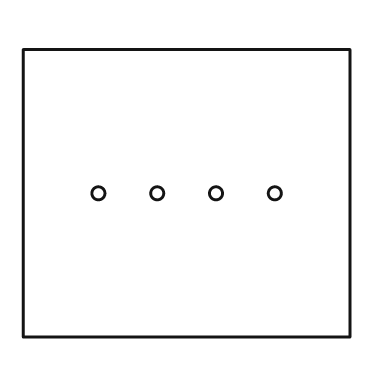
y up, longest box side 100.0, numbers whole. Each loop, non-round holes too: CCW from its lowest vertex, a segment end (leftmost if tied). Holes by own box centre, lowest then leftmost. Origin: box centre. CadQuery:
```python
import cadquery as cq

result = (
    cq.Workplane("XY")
    .moveTo(-50.0, -44.0)
    .lineTo(50.0, -44.0)
    .lineTo(50.0, 44.0)
    .lineTo(-50.0, 44.0)
    .close()
    .moveTo(-27.0, 0.0)
    .circle(2.0)
    .moveTo(-9.0, 0.0)
    .circle(2.0)
    .moveTo(9.0, 0.0)
    .circle(2.0)
    .moveTo(27.0, 0.0)
    .circle(2.0)
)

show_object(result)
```